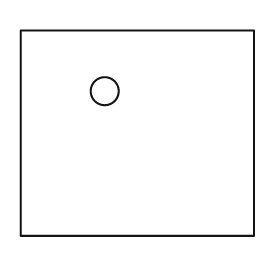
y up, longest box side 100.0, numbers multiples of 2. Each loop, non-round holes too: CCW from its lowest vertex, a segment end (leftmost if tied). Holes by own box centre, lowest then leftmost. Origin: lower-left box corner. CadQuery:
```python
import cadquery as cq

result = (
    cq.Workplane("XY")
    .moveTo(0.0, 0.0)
    .lineTo(100.0, 0.0)
    .lineTo(100.0, 88.0)
    .lineTo(0.0, 88.0)
    .close()
    .moveTo(36.0, 62.0)
    .circle(6.0)
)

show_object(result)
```